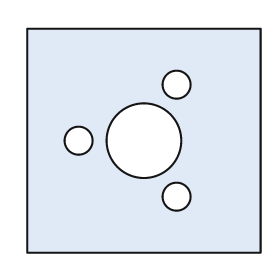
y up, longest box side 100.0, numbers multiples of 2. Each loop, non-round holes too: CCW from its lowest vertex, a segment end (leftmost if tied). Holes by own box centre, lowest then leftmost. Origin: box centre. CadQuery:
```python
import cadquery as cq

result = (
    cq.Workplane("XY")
    .moveTo(-50.0, -48.0)
    .lineTo(50.0, -48.0)
    .lineTo(50.0, 48.0)
    .lineTo(-50.0, 48.0)
    .close()
    .moveTo(14.0, -24.0)
    .circle(6.0)
    .moveTo(-28.0, 0.0)
    .circle(6.0)
    .moveTo(0.0, 0.0)
    .circle(16.0)
    .moveTo(14.0, 24.0)
    .circle(6.0)
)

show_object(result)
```